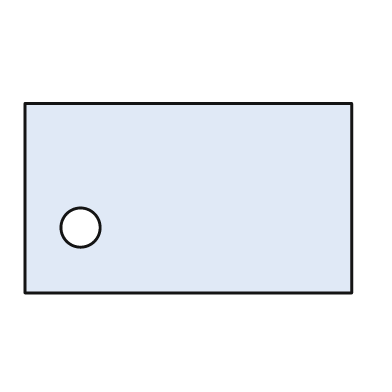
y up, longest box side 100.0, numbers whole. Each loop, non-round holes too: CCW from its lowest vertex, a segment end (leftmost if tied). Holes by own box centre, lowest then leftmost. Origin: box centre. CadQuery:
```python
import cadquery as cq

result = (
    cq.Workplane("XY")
    .moveTo(-50.0, -29.0)
    .lineTo(50.0, -29.0)
    .lineTo(50.0, 29.0)
    .lineTo(-50.0, 29.0)
    .close()
    .moveTo(-33.0, -9.0)
    .circle(6.0)
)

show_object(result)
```